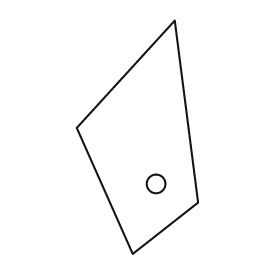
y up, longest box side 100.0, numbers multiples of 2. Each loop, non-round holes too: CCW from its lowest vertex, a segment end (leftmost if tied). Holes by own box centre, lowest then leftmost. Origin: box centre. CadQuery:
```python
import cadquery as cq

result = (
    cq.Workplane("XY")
    .moveTo(-2.0, -50.0)
    .lineTo(26.0, -28.0)
    .lineTo(16.0, 50.0)
    .lineTo(-26.0, 4.0)
    .close()
    .moveTo(8.0, -20.0)
    .circle(4.0)
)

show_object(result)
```